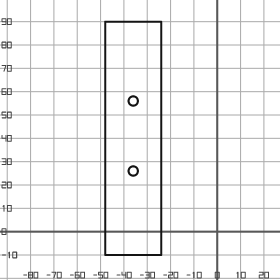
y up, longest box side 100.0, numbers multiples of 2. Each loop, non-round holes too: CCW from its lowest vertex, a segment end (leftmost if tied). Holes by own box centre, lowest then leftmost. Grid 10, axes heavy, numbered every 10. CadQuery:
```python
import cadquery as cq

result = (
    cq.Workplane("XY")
    .moveTo(-48.0, -10.0)
    .lineTo(-24.0, -10.0)
    .lineTo(-24.0, 90.0)
    .lineTo(-48.0, 90.0)
    .close()
    .moveTo(-36.0, 26.0)
    .circle(2.0)
    .moveTo(-36.0, 56.0)
    .circle(2.0)
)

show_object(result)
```